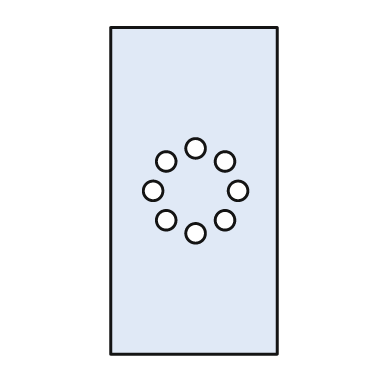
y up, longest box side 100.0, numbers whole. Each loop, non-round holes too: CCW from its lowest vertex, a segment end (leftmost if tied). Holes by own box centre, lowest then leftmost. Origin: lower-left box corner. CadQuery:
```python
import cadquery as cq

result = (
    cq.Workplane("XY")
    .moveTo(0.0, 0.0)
    .lineTo(51.0, 0.0)
    .lineTo(51.0, 100.0)
    .lineTo(0.0, 100.0)
    .close()
    .moveTo(26.0, 37.0)
    .circle(3.0)
    .moveTo(17.0, 41.0)
    .circle(3.0)
    .moveTo(35.0, 41.0)
    .circle(3.0)
    .moveTo(13.0, 50.0)
    .circle(3.0)
    .moveTo(39.0, 50.0)
    .circle(3.0)
    .moveTo(17.0, 59.0)
    .circle(3.0)
    .moveTo(35.0, 59.0)
    .circle(3.0)
    .moveTo(26.0, 63.0)
    .circle(3.0)
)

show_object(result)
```